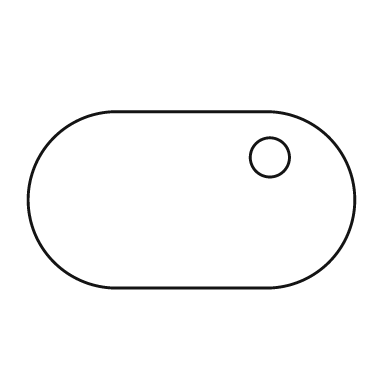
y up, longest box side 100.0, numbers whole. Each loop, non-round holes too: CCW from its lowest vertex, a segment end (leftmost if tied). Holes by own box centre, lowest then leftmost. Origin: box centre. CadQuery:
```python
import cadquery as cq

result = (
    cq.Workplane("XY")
    .moveTo(-23.0, -27.0)
    .lineTo(23.0, -27.0)
    .threePointArc((50.0, 0.0), (23.0, 27.0))
    .lineTo(-23.0, 27.0)
    .threePointArc((-50.0, 0.0), (-23.0, -27.0))
    .close()
    .moveTo(24.0, 13.0)
    .circle(6.0)
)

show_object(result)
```